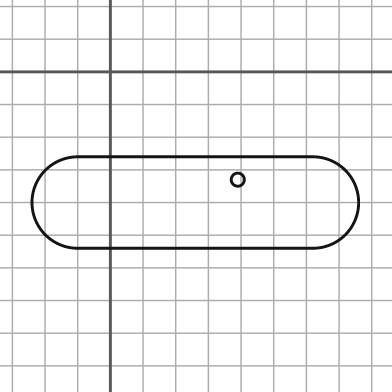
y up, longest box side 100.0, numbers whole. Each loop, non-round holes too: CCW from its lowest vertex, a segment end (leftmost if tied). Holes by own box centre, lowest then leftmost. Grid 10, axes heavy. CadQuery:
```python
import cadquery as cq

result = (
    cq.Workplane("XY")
    .moveTo(-10.0, -54.0)
    .lineTo(62.0, -54.0)
    .threePointArc((76.0, -40.0), (62.0, -26.0))
    .lineTo(-10.0, -26.0)
    .threePointArc((-24.0, -40.0), (-10.0, -54.0))
    .close()
    .moveTo(39.0, -33.0)
    .circle(2.0)
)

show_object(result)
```